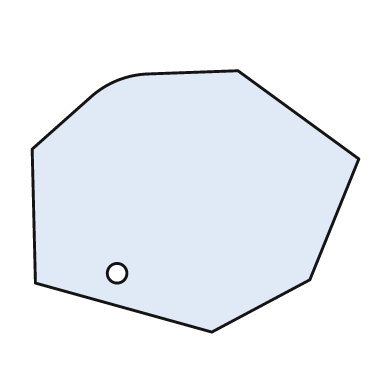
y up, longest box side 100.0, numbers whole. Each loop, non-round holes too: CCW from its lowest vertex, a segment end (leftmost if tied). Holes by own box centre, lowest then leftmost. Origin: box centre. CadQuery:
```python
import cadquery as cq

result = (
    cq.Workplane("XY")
    .moveTo(5.0, -40.0)
    .lineTo(35.0, -24.0)
    .lineTo(50.0, 13.0)
    .lineTo(13.0, 40.0)
    .lineTo(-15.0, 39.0)
    .threePointArc((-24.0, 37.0), (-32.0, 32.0))
    .lineTo(-50.0, 16.0)
    .lineTo(-49.0, -25.0)
    .close()
    .moveTo(-24.0, -22.0)
    .circle(3.0)
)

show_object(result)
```